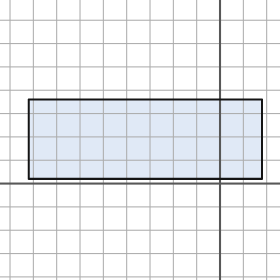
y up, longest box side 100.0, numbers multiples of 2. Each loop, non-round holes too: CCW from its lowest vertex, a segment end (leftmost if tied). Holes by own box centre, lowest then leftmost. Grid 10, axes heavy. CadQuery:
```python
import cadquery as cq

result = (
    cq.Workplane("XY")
    .moveTo(-82.0, 2.0)
    .lineTo(18.0, 2.0)
    .lineTo(18.0, 36.0)
    .lineTo(-82.0, 36.0)
    .close()
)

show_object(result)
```